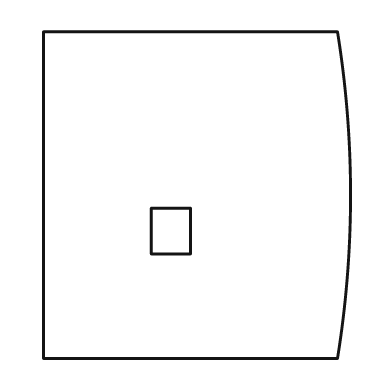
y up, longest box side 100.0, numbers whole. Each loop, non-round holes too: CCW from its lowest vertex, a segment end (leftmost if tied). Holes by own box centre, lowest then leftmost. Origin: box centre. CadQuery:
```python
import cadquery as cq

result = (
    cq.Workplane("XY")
    .moveTo(-47.0, -50.0)
    .lineTo(43.0, -50.0)
    .threePointArc((47.0, 0.0), (43.0, 50.0))
    .lineTo(-47.0, 50.0)
    .close()
    .moveTo(-14.0, -18.0)
    .lineTo(-2.0, -18.0)
    .lineTo(-2.0, -4.0)
    .lineTo(-14.0, -4.0)
    .close()
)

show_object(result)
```